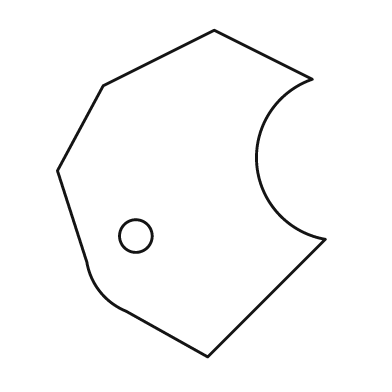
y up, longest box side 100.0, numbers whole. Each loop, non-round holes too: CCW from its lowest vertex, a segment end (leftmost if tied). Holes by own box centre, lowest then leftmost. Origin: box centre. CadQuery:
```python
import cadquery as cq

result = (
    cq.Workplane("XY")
    .moveTo(5.0, -50.0)
    .lineTo(41.0, -14.0)
    .threePointArc((20.0, 9.0), (37.0, 35.0))
    .lineTo(7.0, 50.0)
    .lineTo(-27.0, 33.0)
    .lineTo(-41.0, 7.0)
    .lineTo(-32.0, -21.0)
    .threePointArc((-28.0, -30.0), (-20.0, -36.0))
    .close()
    .moveTo(-17.0, -13.0)
    .circle(5.0)
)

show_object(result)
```